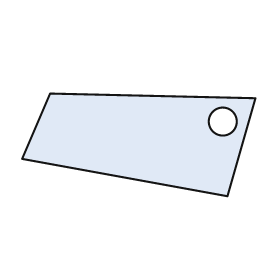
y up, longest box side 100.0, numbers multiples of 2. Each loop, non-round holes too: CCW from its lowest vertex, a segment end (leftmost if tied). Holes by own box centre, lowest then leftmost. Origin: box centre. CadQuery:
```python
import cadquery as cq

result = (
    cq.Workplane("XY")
    .moveTo(38.0, -22.0)
    .lineTo(50.0, 20.0)
    .lineTo(-38.0, 22.0)
    .lineTo(-50.0, -6.0)
    .close()
    .moveTo(36.0, 10.0)
    .circle(6.0)
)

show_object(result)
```